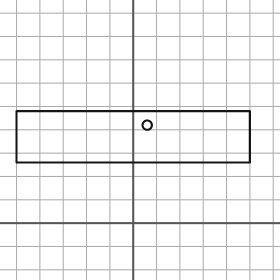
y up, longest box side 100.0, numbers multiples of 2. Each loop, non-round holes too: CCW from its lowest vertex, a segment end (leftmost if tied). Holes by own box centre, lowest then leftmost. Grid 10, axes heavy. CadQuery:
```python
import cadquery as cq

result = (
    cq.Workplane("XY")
    .moveTo(-50.0, 26.0)
    .lineTo(50.0, 26.0)
    .lineTo(50.0, 48.0)
    .lineTo(-50.0, 48.0)
    .close()
    .moveTo(6.0, 42.0)
    .circle(2.0)
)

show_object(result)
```